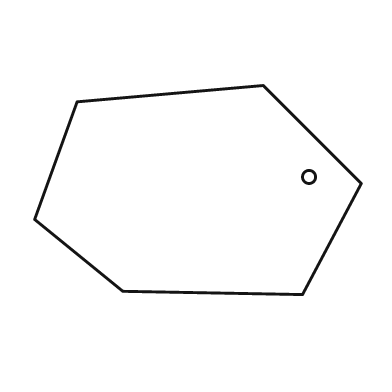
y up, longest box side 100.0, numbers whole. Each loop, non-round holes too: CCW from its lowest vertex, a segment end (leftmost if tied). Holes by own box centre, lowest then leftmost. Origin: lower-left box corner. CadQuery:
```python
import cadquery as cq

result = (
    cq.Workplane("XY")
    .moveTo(82.0, 0.0)
    .lineTo(100.0, 34.0)
    .lineTo(70.0, 64.0)
    .lineTo(13.0, 59.0)
    .lineTo(0.0, 23.0)
    .lineTo(27.0, 1.0)
    .close()
    .moveTo(84.0, 36.0)
    .circle(2.0)
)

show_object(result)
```